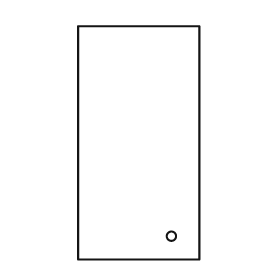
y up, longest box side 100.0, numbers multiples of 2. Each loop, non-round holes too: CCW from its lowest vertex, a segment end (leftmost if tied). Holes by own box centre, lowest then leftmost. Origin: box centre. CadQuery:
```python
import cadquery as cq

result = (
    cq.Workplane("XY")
    .moveTo(-26.0, -50.0)
    .lineTo(26.0, -50.0)
    .lineTo(26.0, 50.0)
    .lineTo(-26.0, 50.0)
    .close()
    .moveTo(14.0, -40.0)
    .circle(2.0)
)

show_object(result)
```